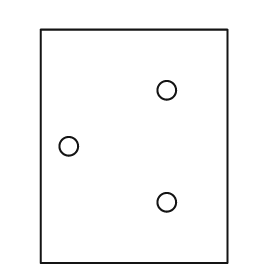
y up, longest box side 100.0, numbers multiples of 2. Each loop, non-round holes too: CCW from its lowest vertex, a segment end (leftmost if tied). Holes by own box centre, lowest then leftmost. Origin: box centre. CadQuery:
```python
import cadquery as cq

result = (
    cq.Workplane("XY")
    .moveTo(-40.0, -50.0)
    .lineTo(40.0, -50.0)
    .lineTo(40.0, 50.0)
    .lineTo(-40.0, 50.0)
    .close()
    .moveTo(14.0, -24.0)
    .circle(4.0)
    .moveTo(-28.0, 0.0)
    .circle(4.0)
    .moveTo(14.0, 24.0)
    .circle(4.0)
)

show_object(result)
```